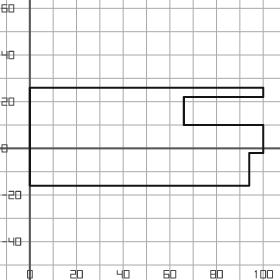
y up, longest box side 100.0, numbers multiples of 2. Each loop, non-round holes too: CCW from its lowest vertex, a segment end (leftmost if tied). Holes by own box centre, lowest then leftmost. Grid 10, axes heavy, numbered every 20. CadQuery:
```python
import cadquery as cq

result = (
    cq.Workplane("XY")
    .moveTo(0.0, -16.0)
    .lineTo(94.0, -16.0)
    .lineTo(94.0, -2.0)
    .lineTo(100.0, -2.0)
    .lineTo(100.0, 10.0)
    .lineTo(66.0, 10.0)
    .lineTo(66.0, 22.0)
    .lineTo(100.0, 22.0)
    .lineTo(100.0, 26.0)
    .lineTo(0.0, 26.0)
    .close()
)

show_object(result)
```